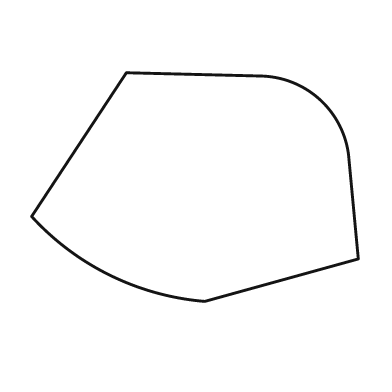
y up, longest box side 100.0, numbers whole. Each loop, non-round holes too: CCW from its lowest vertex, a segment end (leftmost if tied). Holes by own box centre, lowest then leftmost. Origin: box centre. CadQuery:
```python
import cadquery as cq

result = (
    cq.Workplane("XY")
    .moveTo(3.0, -35.0)
    .lineTo(50.0, -22.0)
    .lineTo(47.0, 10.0)
    .threePointArc((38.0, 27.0), (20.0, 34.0))
    .lineTo(-21.0, 35.0)
    .lineTo(-50.0, -9.0)
    .threePointArc((-26.0, -27.0), (3.0, -35.0))
    .close()
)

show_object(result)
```